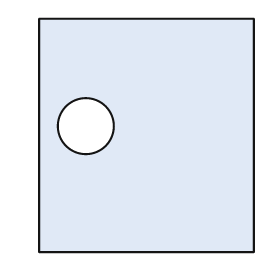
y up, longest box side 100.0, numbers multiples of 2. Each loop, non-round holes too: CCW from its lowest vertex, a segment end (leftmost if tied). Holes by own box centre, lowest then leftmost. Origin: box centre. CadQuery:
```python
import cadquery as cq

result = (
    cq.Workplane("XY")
    .moveTo(-46.0, -50.0)
    .lineTo(46.0, -50.0)
    .lineTo(46.0, 50.0)
    .lineTo(-46.0, 50.0)
    .close()
    .moveTo(-26.0, 4.0)
    .circle(12.0)
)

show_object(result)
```